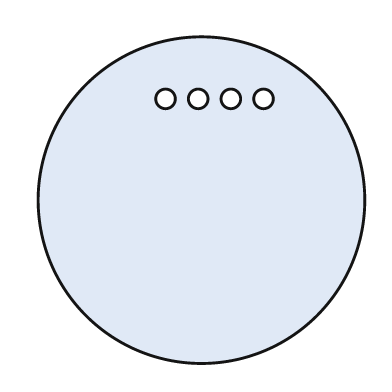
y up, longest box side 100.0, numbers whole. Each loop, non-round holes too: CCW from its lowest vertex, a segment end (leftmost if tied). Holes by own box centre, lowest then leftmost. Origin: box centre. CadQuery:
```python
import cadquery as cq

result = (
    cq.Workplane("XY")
    .moveTo(0.0, 0.0)
    .circle(50.0)
    .moveTo(-11.0, 31.0)
    .circle(3.0)
    .moveTo(-1.0, 31.0)
    .circle(3.0)
    .moveTo(9.0, 31.0)
    .circle(3.0)
    .moveTo(19.0, 31.0)
    .circle(3.0)
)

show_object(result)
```